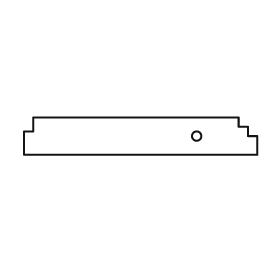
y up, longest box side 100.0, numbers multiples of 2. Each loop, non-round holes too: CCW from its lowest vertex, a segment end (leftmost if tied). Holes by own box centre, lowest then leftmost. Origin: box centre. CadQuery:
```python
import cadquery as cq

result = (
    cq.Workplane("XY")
    .moveTo(-50.0, -8.0)
    .lineTo(50.0, -8.0)
    .lineTo(50.0, 0.0)
    .lineTo(46.0, 0.0)
    .lineTo(46.0, 4.0)
    .lineTo(42.0, 4.0)
    .lineTo(42.0, 8.0)
    .lineTo(-46.0, 8.0)
    .lineTo(-46.0, 2.0)
    .lineTo(-50.0, 2.0)
    .close()
    .moveTo(24.0, 0.0)
    .circle(2.0)
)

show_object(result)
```